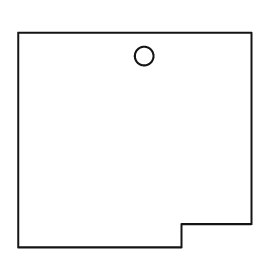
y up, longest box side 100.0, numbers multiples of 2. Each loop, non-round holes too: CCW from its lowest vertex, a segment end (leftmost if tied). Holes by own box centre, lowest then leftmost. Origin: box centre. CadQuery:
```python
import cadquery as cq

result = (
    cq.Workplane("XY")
    .moveTo(-50.0, -46.0)
    .lineTo(20.0, -46.0)
    .lineTo(20.0, -36.0)
    .lineTo(50.0, -36.0)
    .lineTo(50.0, 46.0)
    .lineTo(-50.0, 46.0)
    .close()
    .moveTo(4.0, 36.0)
    .circle(4.0)
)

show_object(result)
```